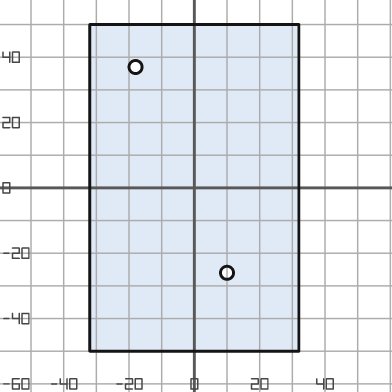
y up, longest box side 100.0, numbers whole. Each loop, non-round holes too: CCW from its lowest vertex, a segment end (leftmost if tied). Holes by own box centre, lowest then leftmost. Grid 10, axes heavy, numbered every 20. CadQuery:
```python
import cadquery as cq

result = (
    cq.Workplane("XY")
    .moveTo(-32.0, -50.0)
    .lineTo(32.0, -50.0)
    .lineTo(32.0, 50.0)
    .lineTo(-32.0, 50.0)
    .close()
    .moveTo(10.0, -26.0)
    .circle(2.0)
    .moveTo(-18.0, 37.0)
    .circle(2.0)
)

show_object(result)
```